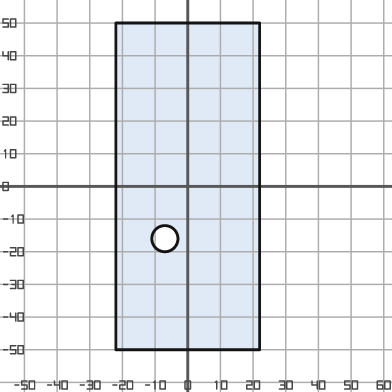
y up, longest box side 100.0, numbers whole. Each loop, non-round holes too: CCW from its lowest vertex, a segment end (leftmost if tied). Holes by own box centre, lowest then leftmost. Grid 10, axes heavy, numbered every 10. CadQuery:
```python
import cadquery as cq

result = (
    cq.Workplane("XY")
    .moveTo(-22.0, -50.0)
    .lineTo(22.0, -50.0)
    .lineTo(22.0, 50.0)
    .lineTo(-22.0, 50.0)
    .close()
    .moveTo(-7.0, -16.0)
    .circle(4.0)
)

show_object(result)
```